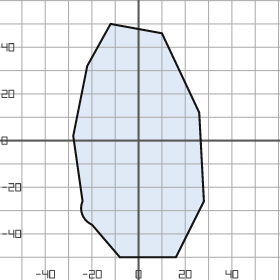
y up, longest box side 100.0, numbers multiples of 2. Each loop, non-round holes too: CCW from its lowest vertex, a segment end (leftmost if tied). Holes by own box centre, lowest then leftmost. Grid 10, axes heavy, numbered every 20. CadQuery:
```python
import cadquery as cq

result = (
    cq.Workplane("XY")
    .moveTo(-8.0, -50.0)
    .lineTo(16.0, -50.0)
    .lineTo(28.0, -26.0)
    .lineTo(26.0, 12.0)
    .lineTo(10.0, 46.0)
    .lineTo(-12.0, 50.0)
    .lineTo(-22.0, 32.0)
    .lineTo(-28.0, 2.0)
    .lineTo(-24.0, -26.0)
    .threePointArc((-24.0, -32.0), (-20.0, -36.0))
    .close()
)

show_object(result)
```